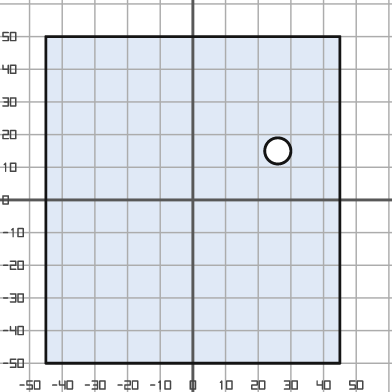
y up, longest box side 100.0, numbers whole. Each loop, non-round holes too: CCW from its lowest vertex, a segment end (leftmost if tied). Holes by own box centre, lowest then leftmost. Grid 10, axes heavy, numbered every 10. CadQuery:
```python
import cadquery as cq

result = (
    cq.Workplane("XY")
    .moveTo(-45.0, -50.0)
    .lineTo(45.0, -50.0)
    .lineTo(45.0, 50.0)
    .lineTo(-45.0, 50.0)
    .close()
    .moveTo(26.0, 15.0)
    .circle(4.0)
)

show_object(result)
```